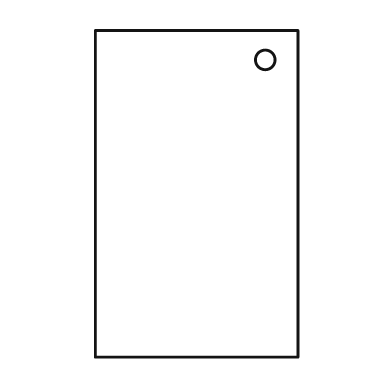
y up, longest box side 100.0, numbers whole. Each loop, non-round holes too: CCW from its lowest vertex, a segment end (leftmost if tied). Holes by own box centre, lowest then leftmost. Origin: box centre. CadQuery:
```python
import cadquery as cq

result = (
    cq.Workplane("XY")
    .moveTo(-31.0, -50.0)
    .lineTo(31.0, -50.0)
    .lineTo(31.0, 50.0)
    .lineTo(-31.0, 50.0)
    .close()
    .moveTo(21.0, 41.0)
    .circle(3.0)
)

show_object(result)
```